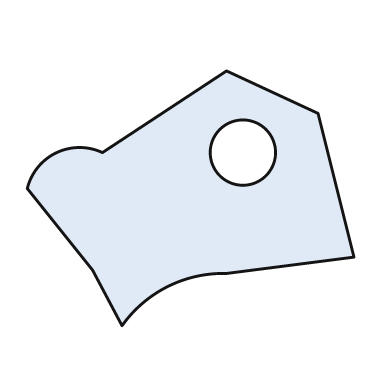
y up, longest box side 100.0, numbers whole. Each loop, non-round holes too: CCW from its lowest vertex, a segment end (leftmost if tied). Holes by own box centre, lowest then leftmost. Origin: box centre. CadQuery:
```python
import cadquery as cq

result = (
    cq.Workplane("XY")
    .moveTo(-21.0, -39.0)
    .threePointArc((-7.0, -27.0), (11.0, -23.0))
    .lineTo(50.0, -18.0)
    .lineTo(39.0, 26.0)
    .lineTo(11.0, 39.0)
    .lineTo(-27.0, 14.0)
    .threePointArc((-41.0, 14.0), (-50.0, 3.0))
    .lineTo(-30.0, -22.0)
    .close()
    .moveTo(16.0, 14.0)
    .circle(10.0)
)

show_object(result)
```